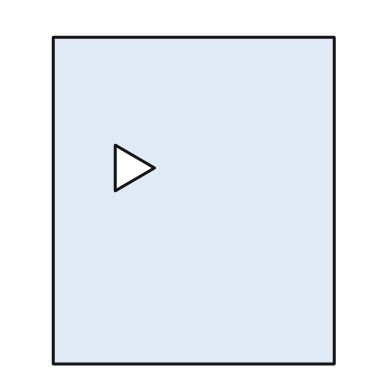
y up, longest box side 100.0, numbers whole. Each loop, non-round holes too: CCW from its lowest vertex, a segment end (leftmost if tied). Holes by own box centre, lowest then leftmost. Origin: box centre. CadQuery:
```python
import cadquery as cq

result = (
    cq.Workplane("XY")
    .moveTo(-43.0, -50.0)
    .lineTo(43.0, -50.0)
    .lineTo(43.0, 50.0)
    .lineTo(-43.0, 50.0)
    .close()
    .moveTo(-24.0, 3.0)
    .lineTo(-12.0, 10.0)
    .lineTo(-24.0, 17.0)
    .close()
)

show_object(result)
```